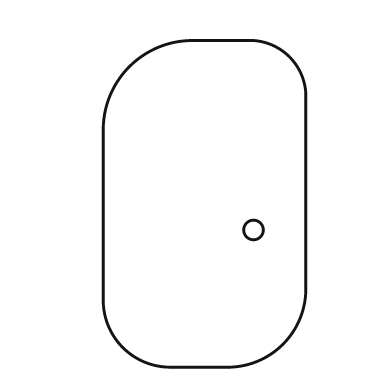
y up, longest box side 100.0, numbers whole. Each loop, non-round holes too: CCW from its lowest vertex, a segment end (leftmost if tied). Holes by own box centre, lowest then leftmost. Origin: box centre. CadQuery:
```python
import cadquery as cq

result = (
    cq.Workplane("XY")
    .moveTo(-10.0, -50.0)
    .lineTo(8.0, -50.0)
    .threePointArc((24.0, -43.0), (31.0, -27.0))
    .lineTo(31.0, 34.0)
    .threePointArc((26.0, 45.0), (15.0, 50.0))
    .lineTo(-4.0, 50.0)
    .threePointArc((-23.0, 42.0), (-31.0, 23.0))
    .lineTo(-31.0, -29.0)
    .threePointArc((-25.0, -44.0), (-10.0, -50.0))
    .close()
    .moveTo(15.0, -8.0)
    .circle(3.0)
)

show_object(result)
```